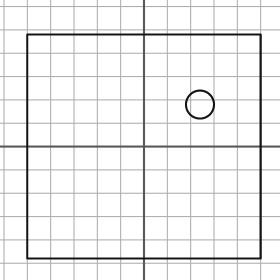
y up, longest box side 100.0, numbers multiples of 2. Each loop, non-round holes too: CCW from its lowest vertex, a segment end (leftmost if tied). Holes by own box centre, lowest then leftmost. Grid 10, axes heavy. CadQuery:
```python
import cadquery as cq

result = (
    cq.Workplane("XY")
    .moveTo(-50.0, -48.0)
    .lineTo(50.0, -48.0)
    .lineTo(50.0, 48.0)
    .lineTo(-50.0, 48.0)
    .close()
    .moveTo(24.0, 18.0)
    .circle(6.0)
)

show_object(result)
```